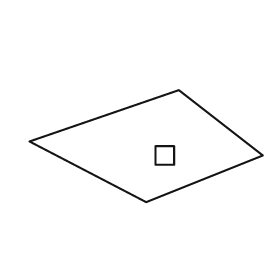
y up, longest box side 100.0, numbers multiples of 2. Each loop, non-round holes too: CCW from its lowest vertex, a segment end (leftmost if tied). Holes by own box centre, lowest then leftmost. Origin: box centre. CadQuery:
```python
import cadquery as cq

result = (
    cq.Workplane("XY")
    .moveTo(0.0, -24.0)
    .lineTo(50.0, -4.0)
    .lineTo(14.0, 24.0)
    .lineTo(-50.0, 2.0)
    .close()
    .moveTo(4.0, -8.0)
    .lineTo(12.0, -8.0)
    .lineTo(12.0, 0.0)
    .lineTo(4.0, 0.0)
    .close()
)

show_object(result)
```